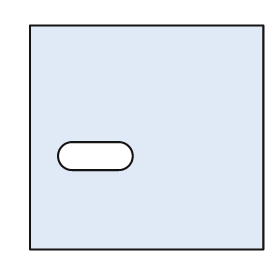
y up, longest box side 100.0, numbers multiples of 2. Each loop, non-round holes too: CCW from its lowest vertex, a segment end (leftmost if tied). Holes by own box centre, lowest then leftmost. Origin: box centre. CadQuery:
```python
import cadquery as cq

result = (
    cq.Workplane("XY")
    .moveTo(-50.0, -48.0)
    .lineTo(50.0, -48.0)
    .lineTo(50.0, 48.0)
    .lineTo(-50.0, 48.0)
    .close()
    .moveTo(-32.0, -14.0)
    .lineTo(-12.0, -14.0)
    .threePointArc((-6.0, -8.0), (-12.0, -2.0))
    .lineTo(-32.0, -2.0)
    .threePointArc((-38.0, -8.0), (-32.0, -14.0))
    .close()
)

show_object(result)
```